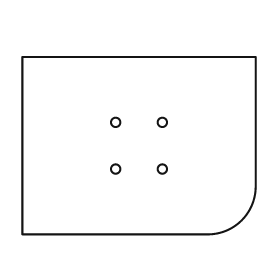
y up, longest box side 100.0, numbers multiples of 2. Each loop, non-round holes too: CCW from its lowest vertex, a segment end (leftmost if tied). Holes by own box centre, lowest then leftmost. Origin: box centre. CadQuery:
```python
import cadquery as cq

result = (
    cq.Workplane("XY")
    .moveTo(-50.0, -38.0)
    .lineTo(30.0, -38.0)
    .threePointArc((44.0, -32.0), (50.0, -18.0))
    .lineTo(50.0, 38.0)
    .lineTo(-50.0, 38.0)
    .close()
    .moveTo(-10.0, -10.0)
    .circle(2.0)
    .moveTo(10.0, -10.0)
    .circle(2.0)
    .moveTo(-10.0, 10.0)
    .circle(2.0)
    .moveTo(10.0, 10.0)
    .circle(2.0)
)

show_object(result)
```